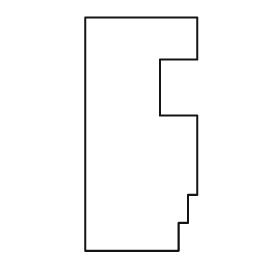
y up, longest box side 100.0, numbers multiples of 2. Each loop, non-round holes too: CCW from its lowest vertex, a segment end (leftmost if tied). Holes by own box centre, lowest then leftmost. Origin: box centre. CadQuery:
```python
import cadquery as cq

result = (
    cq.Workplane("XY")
    .moveTo(-24.0, -50.0)
    .lineTo(16.0, -50.0)
    .lineTo(16.0, -38.0)
    .lineTo(20.0, -38.0)
    .lineTo(20.0, -26.0)
    .lineTo(24.0, -26.0)
    .lineTo(24.0, 8.0)
    .lineTo(8.0, 8.0)
    .lineTo(8.0, 32.0)
    .lineTo(24.0, 32.0)
    .lineTo(24.0, 50.0)
    .lineTo(-24.0, 50.0)
    .close()
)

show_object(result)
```